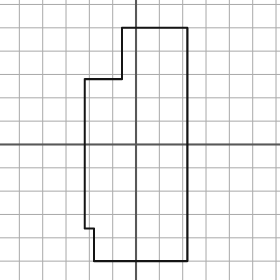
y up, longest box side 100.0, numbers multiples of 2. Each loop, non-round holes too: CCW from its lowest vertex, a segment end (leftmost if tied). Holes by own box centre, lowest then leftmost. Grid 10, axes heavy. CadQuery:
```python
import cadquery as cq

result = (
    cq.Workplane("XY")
    .moveTo(-18.0, -50.0)
    .lineTo(22.0, -50.0)
    .lineTo(22.0, 50.0)
    .lineTo(-6.0, 50.0)
    .lineTo(-6.0, 28.0)
    .lineTo(-22.0, 28.0)
    .lineTo(-22.0, -36.0)
    .lineTo(-18.0, -36.0)
    .close()
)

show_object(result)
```